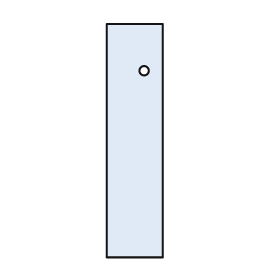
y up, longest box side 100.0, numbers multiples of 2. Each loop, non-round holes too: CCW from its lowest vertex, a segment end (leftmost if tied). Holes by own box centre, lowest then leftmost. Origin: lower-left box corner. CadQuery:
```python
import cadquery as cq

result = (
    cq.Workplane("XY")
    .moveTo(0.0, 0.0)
    .lineTo(24.0, 0.0)
    .lineTo(24.0, 100.0)
    .lineTo(0.0, 100.0)
    .close()
    .moveTo(16.0, 80.0)
    .circle(2.0)
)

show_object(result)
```